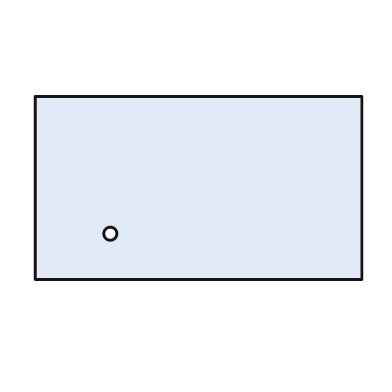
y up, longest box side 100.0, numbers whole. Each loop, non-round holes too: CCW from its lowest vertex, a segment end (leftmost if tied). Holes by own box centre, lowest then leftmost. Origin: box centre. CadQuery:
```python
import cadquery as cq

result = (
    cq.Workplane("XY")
    .moveTo(-50.0, -28.0)
    .lineTo(50.0, -28.0)
    .lineTo(50.0, 28.0)
    .lineTo(-50.0, 28.0)
    .close()
    .moveTo(-27.0, -14.0)
    .circle(2.0)
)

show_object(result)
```